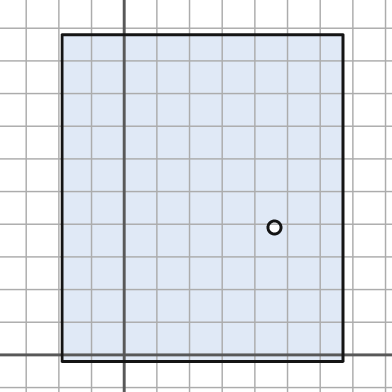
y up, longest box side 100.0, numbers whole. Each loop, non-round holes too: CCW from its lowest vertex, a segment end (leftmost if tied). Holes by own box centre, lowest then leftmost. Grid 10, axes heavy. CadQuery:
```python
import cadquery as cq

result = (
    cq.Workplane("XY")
    .moveTo(-19.0, -2.0)
    .lineTo(67.0, -2.0)
    .lineTo(67.0, 98.0)
    .lineTo(-19.0, 98.0)
    .close()
    .moveTo(46.0, 39.0)
    .circle(2.0)
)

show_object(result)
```